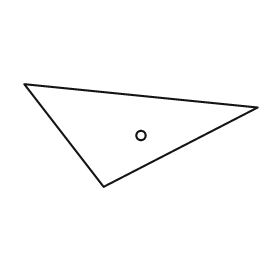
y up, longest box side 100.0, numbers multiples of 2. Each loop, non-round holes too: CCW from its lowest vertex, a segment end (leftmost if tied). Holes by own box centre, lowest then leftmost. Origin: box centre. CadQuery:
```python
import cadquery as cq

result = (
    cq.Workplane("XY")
    .moveTo(-16.0, -22.0)
    .lineTo(50.0, 12.0)
    .lineTo(-50.0, 22.0)
    .close()
    .moveTo(0.0, 0.0)
    .circle(2.0)
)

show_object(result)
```